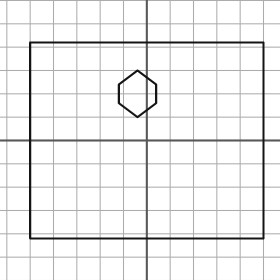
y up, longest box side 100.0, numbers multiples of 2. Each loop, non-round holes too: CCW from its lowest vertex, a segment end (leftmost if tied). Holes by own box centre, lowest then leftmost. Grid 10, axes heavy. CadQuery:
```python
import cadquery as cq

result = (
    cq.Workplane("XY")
    .moveTo(-50.0, -42.0)
    .lineTo(50.0, -42.0)
    .lineTo(50.0, 42.0)
    .lineTo(-50.0, 42.0)
    .close()
    .moveTo(-4.0, 10.0)
    .lineTo(4.0, 16.0)
    .lineTo(4.0, 24.0)
    .lineTo(-4.0, 30.0)
    .lineTo(-12.0, 24.0)
    .lineTo(-12.0, 16.0)
    .close()
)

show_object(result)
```